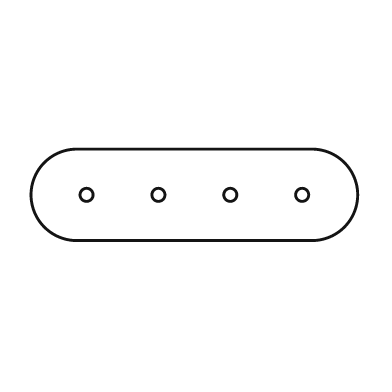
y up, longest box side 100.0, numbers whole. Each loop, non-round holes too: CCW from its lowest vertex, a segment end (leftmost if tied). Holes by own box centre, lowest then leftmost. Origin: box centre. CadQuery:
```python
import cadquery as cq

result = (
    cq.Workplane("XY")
    .moveTo(-36.0, -14.0)
    .lineTo(36.0, -14.0)
    .threePointArc((50.0, 0.0), (36.0, 14.0))
    .lineTo(-36.0, 14.0)
    .threePointArc((-50.0, 0.0), (-36.0, -14.0))
    .close()
    .moveTo(-33.0, 0.0)
    .circle(2.0)
    .moveTo(-11.0, 0.0)
    .circle(2.0)
    .moveTo(11.0, 0.0)
    .circle(2.0)
    .moveTo(33.0, 0.0)
    .circle(2.0)
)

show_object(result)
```